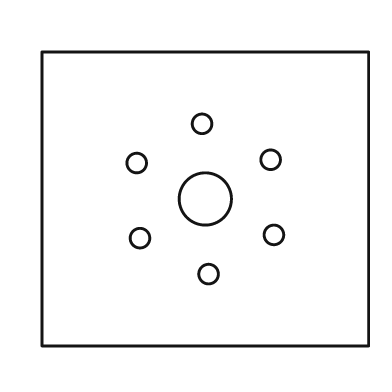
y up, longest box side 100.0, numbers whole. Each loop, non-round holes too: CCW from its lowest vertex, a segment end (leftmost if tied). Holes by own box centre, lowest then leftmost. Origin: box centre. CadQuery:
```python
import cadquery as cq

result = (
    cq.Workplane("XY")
    .moveTo(-50.0, -45.0)
    .lineTo(50.0, -45.0)
    .lineTo(50.0, 45.0)
    .lineTo(-50.0, 45.0)
    .close()
    .moveTo(1.0, -23.0)
    .circle(3.0)
    .moveTo(-20.0, -12.0)
    .circle(3.0)
    .moveTo(21.0, -11.0)
    .circle(3.0)
    .moveTo(0.0, 0.0)
    .circle(8.0)
    .moveTo(-21.0, 11.0)
    .circle(3.0)
    .moveTo(20.0, 12.0)
    .circle(3.0)
    .moveTo(-1.0, 23.0)
    .circle(3.0)
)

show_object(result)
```